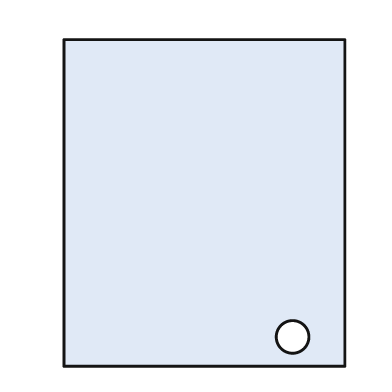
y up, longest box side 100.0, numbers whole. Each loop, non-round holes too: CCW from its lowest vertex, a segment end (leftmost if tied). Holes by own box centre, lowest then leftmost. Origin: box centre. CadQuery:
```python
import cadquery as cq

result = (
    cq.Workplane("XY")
    .moveTo(-43.0, -50.0)
    .lineTo(43.0, -50.0)
    .lineTo(43.0, 50.0)
    .lineTo(-43.0, 50.0)
    .close()
    .moveTo(27.0, -41.0)
    .circle(5.0)
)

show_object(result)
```